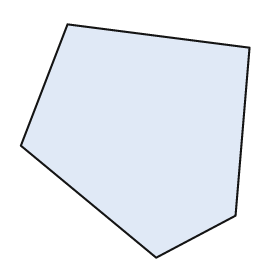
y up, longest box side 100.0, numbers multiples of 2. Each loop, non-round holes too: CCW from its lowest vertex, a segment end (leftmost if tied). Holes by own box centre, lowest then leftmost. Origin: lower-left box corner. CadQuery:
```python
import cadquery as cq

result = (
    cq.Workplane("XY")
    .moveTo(58.0, 0.0)
    .lineTo(92.0, 18.0)
    .lineTo(98.0, 90.0)
    .lineTo(20.0, 100.0)
    .lineTo(0.0, 48.0)
    .close()
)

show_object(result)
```